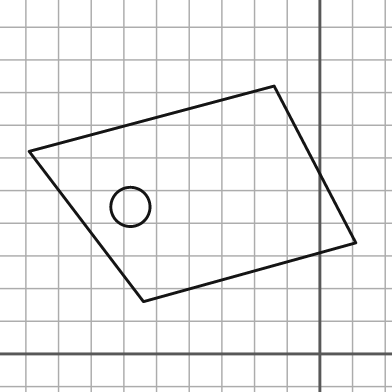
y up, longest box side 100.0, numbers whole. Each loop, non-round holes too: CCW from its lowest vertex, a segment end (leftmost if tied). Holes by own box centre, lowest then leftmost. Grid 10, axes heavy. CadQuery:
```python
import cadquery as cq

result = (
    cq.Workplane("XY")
    .moveTo(-54.0, 16.0)
    .lineTo(11.0, 34.0)
    .lineTo(-14.0, 82.0)
    .lineTo(-89.0, 62.0)
    .close()
    .moveTo(-58.0, 45.0)
    .circle(6.0)
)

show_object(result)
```